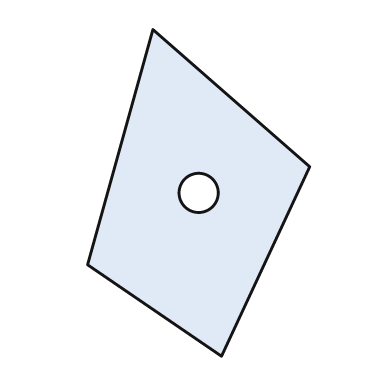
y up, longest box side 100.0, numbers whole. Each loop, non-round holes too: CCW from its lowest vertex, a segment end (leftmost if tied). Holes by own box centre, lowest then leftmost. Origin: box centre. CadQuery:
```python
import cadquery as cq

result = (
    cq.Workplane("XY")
    .moveTo(7.0, -50.0)
    .lineTo(34.0, 8.0)
    .lineTo(-14.0, 50.0)
    .lineTo(-34.0, -22.0)
    .close()
    .moveTo(0.0, 0.0)
    .circle(6.0)
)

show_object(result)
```